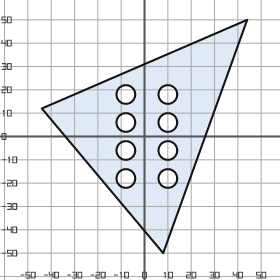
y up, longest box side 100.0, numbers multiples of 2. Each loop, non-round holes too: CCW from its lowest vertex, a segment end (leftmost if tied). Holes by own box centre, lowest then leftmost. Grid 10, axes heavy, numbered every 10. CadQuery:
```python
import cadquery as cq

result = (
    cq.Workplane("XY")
    .moveTo(8.0, -50.0)
    .lineTo(44.0, 50.0)
    .lineTo(-44.0, 12.0)
    .close()
    .moveTo(-8.0, -18.0)
    .circle(4.0)
    .moveTo(10.0, -18.0)
    .circle(4.0)
    .moveTo(-8.0, -6.0)
    .circle(4.0)
    .moveTo(10.0, -6.0)
    .circle(4.0)
    .moveTo(-8.0, 6.0)
    .circle(4.0)
    .moveTo(10.0, 6.0)
    .circle(4.0)
    .moveTo(-8.0, 18.0)
    .circle(4.0)
    .moveTo(10.0, 18.0)
    .circle(4.0)
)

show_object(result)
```